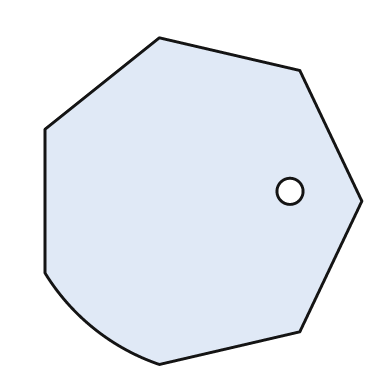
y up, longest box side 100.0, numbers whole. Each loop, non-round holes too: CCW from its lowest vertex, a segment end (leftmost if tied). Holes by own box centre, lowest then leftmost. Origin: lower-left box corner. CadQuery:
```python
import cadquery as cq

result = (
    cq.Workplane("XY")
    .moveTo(35.0, 0.0)
    .lineTo(78.0, 10.0)
    .lineTo(97.0, 50.0)
    .lineTo(78.0, 90.0)
    .lineTo(35.0, 100.0)
    .lineTo(0.0, 72.0)
    .lineTo(0.0, 28.0)
    .threePointArc((15.0, 11.0), (35.0, 0.0))
    .close()
    .moveTo(75.0, 53.0)
    .circle(4.0)
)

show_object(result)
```